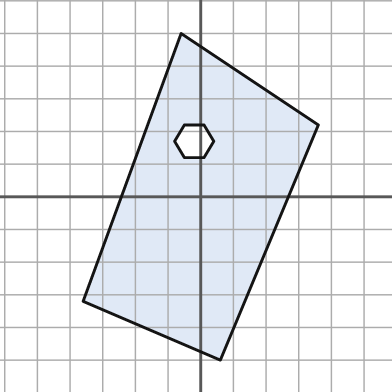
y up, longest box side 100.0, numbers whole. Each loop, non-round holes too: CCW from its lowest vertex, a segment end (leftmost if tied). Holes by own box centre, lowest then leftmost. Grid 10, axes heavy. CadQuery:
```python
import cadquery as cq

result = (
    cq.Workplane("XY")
    .moveTo(6.0, -50.0)
    .lineTo(36.0, 22.0)
    .lineTo(-6.0, 50.0)
    .lineTo(-36.0, -32.0)
    .close()
    .moveTo(-5.0, 12.0)
    .lineTo(1.0, 12.0)
    .lineTo(4.0, 17.0)
    .lineTo(1.0, 22.0)
    .lineTo(-5.0, 22.0)
    .lineTo(-8.0, 17.0)
    .close()
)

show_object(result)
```